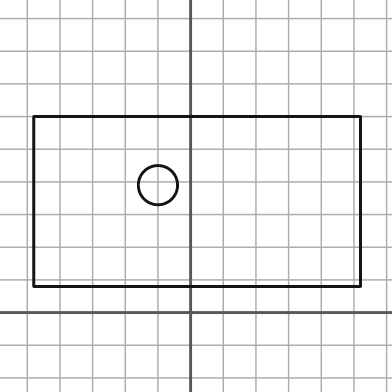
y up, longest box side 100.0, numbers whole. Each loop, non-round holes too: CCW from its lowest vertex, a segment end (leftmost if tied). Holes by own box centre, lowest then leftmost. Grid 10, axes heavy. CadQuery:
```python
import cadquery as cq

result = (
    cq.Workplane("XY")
    .moveTo(-48.0, 8.0)
    .lineTo(52.0, 8.0)
    .lineTo(52.0, 60.0)
    .lineTo(-48.0, 60.0)
    .close()
    .moveTo(-10.0, 39.0)
    .circle(6.0)
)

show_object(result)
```